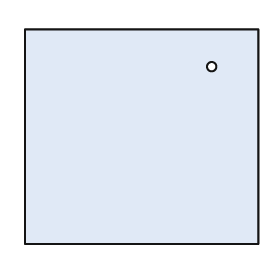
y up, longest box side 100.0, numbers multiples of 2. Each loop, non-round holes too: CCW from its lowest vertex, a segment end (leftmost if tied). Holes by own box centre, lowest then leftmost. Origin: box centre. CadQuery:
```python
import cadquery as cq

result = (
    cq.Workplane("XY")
    .moveTo(-50.0, -46.0)
    .lineTo(50.0, -46.0)
    .lineTo(50.0, 46.0)
    .lineTo(-50.0, 46.0)
    .close()
    .moveTo(30.0, 30.0)
    .circle(2.0)
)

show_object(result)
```